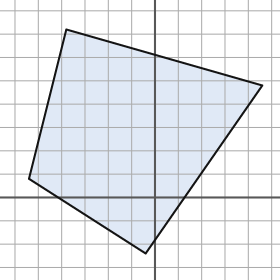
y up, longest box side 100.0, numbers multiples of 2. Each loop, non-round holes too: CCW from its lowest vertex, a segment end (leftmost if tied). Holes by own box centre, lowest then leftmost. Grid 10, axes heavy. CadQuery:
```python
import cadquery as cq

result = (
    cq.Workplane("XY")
    .moveTo(-4.0, -24.0)
    .lineTo(46.0, 48.0)
    .lineTo(-38.0, 72.0)
    .lineTo(-54.0, 8.0)
    .close()
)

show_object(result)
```